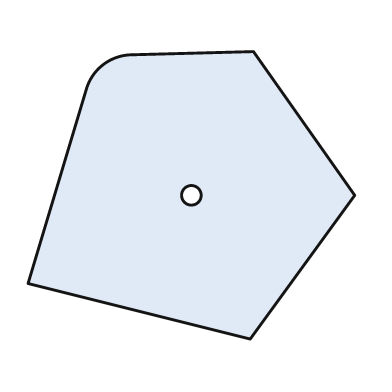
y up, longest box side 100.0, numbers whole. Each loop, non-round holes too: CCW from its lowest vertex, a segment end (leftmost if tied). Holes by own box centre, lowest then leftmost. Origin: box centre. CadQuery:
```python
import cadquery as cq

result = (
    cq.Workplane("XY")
    .moveTo(18.0, -44.0)
    .lineTo(50.0, 0.0)
    .lineTo(19.0, 44.0)
    .lineTo(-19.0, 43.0)
    .threePointArc((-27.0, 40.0), (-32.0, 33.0))
    .lineTo(-50.0, -27.0)
    .close()
    .moveTo(0.0, 0.0)
    .circle(3.0)
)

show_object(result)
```